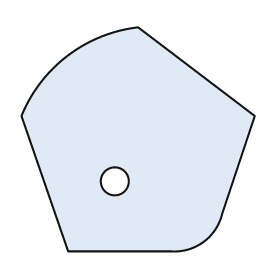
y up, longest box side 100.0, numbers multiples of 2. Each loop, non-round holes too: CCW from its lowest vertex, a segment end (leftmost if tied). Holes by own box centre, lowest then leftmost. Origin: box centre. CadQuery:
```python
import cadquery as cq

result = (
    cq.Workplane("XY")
    .moveTo(-30.0, -48.0)
    .lineTo(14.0, -48.0)
    .threePointArc((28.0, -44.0), (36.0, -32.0))
    .lineTo(50.0, 10.0)
    .lineTo(0.0, 48.0)
    .threePointArc((-30.0, 36.0), (-50.0, 10.0))
    .close()
    .moveTo(-10.0, -18.0)
    .circle(6.0)
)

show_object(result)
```